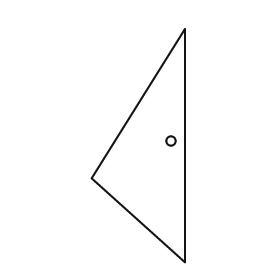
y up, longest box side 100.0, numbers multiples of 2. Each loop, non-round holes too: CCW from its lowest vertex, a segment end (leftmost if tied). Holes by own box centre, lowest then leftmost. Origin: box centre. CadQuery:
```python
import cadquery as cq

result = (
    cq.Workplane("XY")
    .moveTo(20.0, -50.0)
    .lineTo(20.0, 50.0)
    .lineTo(-20.0, -14.0)
    .close()
    .moveTo(14.0, 2.0)
    .circle(2.0)
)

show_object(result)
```